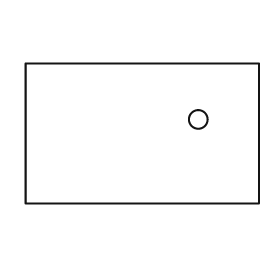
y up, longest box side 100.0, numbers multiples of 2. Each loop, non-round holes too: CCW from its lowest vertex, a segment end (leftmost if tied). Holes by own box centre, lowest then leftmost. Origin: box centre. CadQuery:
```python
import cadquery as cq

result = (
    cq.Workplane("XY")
    .moveTo(-50.0, -30.0)
    .lineTo(50.0, -30.0)
    .lineTo(50.0, 30.0)
    .lineTo(-50.0, 30.0)
    .close()
    .moveTo(24.0, 6.0)
    .circle(4.0)
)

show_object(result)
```